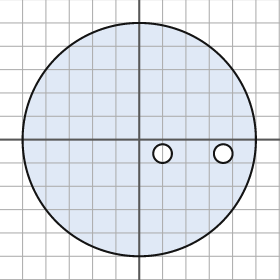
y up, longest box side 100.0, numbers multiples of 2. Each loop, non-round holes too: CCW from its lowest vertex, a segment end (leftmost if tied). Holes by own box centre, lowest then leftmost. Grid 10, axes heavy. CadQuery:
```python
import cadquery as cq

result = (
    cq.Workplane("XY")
    .moveTo(0.0, 0.0)
    .circle(50.0)
    .moveTo(10.0, -6.0)
    .circle(4.0)
    .moveTo(36.0, -6.0)
    .circle(4.0)
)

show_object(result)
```